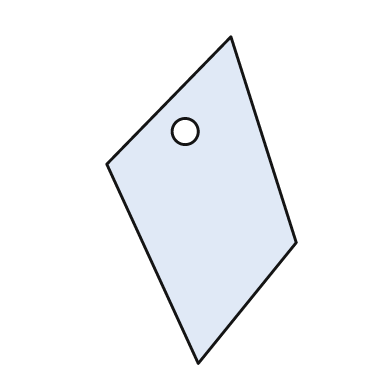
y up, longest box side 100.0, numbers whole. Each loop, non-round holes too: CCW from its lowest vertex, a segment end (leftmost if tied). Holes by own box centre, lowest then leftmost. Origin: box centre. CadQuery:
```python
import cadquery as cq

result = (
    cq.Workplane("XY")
    .moveTo(-1.0, -50.0)
    .lineTo(29.0, -13.0)
    .lineTo(9.0, 50.0)
    .lineTo(-29.0, 11.0)
    .close()
    .moveTo(-5.0, 21.0)
    .circle(4.0)
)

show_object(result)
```